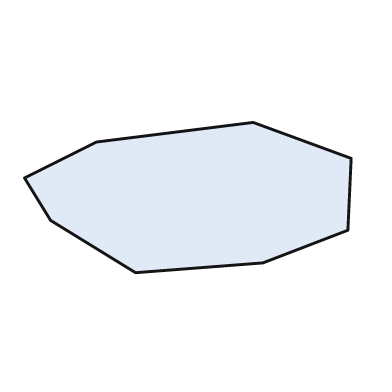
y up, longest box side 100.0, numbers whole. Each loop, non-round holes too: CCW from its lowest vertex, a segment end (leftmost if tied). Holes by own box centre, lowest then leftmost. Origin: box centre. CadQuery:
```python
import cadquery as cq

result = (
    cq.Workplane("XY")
    .moveTo(-16.0, -23.0)
    .lineTo(23.0, -20.0)
    .lineTo(49.0, -10.0)
    .lineTo(50.0, 12.0)
    .lineTo(20.0, 23.0)
    .lineTo(-28.0, 17.0)
    .lineTo(-50.0, 6.0)
    .lineTo(-42.0, -7.0)
    .close()
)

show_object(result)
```